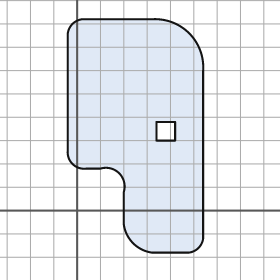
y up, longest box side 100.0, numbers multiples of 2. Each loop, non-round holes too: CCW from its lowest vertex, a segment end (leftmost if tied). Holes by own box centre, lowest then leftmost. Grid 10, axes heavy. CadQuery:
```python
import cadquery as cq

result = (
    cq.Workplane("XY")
    .moveTo(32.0, -18.0)
    .lineTo(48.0, -18.0)
    .threePointArc((52.0, -16.0), (54.0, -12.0))
    .lineTo(54.0, 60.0)
    .threePointArc((48.0, 76.0), (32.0, 82.0))
    .lineTo(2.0, 82.0)
    .threePointArc((-2.0, 80.0), (-4.0, 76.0))
    .lineTo(-4.0, 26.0)
    .threePointArc((-2.0, 20.0), (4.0, 18.0))
    .lineTo(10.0, 18.0)
    .threePointArc((18.0, 16.0), (20.0, 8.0))
    .lineTo(20.0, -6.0)
    .threePointArc((24.0, -14.0), (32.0, -18.0))
    .close()
    .moveTo(34.0, 30.0)
    .lineTo(42.0, 30.0)
    .lineTo(42.0, 38.0)
    .lineTo(34.0, 38.0)
    .close()
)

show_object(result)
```